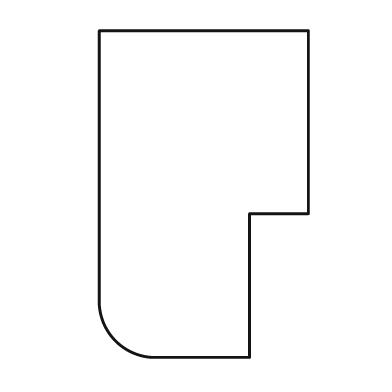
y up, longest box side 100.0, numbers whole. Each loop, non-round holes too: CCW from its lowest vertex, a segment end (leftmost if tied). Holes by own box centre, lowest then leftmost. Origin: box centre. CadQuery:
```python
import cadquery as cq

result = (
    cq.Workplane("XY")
    .moveTo(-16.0, -50.0)
    .lineTo(14.0, -50.0)
    .lineTo(14.0, -6.0)
    .lineTo(32.0, -6.0)
    .lineTo(32.0, 50.0)
    .lineTo(-32.0, 50.0)
    .lineTo(-32.0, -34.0)
    .threePointArc((-27.0, -45.0), (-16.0, -50.0))
    .close()
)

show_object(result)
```